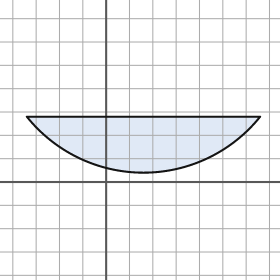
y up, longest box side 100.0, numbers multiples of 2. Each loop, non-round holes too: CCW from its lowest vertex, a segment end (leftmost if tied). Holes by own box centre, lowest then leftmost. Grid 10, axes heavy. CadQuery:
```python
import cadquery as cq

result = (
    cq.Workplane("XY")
    .moveTo(-34.0, 28.0)
    .threePointArc((16.0, 4.0), (66.0, 28.0))
    .close()
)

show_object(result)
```